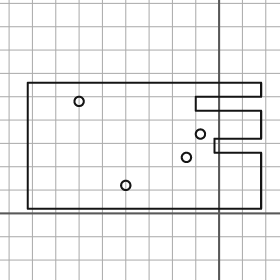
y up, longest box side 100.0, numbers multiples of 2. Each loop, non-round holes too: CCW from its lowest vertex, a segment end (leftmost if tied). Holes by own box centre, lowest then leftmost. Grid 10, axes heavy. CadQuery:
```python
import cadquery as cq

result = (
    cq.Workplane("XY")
    .moveTo(-82.0, 2.0)
    .lineTo(18.0, 2.0)
    .lineTo(18.0, 26.0)
    .lineTo(-2.0, 26.0)
    .lineTo(-2.0, 32.0)
    .lineTo(18.0, 32.0)
    .lineTo(18.0, 44.0)
    .lineTo(-10.0, 44.0)
    .lineTo(-10.0, 50.0)
    .lineTo(18.0, 50.0)
    .lineTo(18.0, 56.0)
    .lineTo(-82.0, 56.0)
    .close()
    .moveTo(-40.0, 12.0)
    .circle(2.0)
    .moveTo(-14.0, 24.0)
    .circle(2.0)
    .moveTo(-8.0, 34.0)
    .circle(2.0)
    .moveTo(-60.0, 48.0)
    .circle(2.0)
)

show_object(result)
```